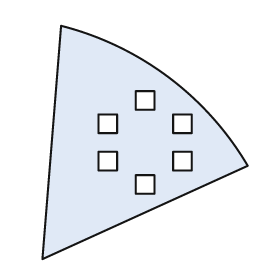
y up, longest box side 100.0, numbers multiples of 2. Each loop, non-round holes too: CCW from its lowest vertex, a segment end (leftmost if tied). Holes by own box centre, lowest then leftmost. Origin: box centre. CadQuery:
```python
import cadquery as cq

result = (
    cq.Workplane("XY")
    .moveTo(-44.0, -50.0)
    .lineTo(44.0, -10.0)
    .threePointArc((10.0, 28.0), (-36.0, 50.0))
    .close()
    .moveTo(-4.0, -22.0)
    .lineTo(4.0, -22.0)
    .lineTo(4.0, -14.0)
    .lineTo(-4.0, -14.0)
    .close()
    .moveTo(-20.0, -12.0)
    .lineTo(-12.0, -12.0)
    .lineTo(-12.0, -4.0)
    .lineTo(-20.0, -4.0)
    .close()
    .moveTo(12.0, -12.0)
    .lineTo(20.0, -12.0)
    .lineTo(20.0, -4.0)
    .lineTo(12.0, -4.0)
    .close()
    .moveTo(-20.0, 4.0)
    .lineTo(-12.0, 4.0)
    .lineTo(-12.0, 12.0)
    .lineTo(-20.0, 12.0)
    .close()
    .moveTo(12.0, 4.0)
    .lineTo(20.0, 4.0)
    .lineTo(20.0, 12.0)
    .lineTo(12.0, 12.0)
    .close()
    .moveTo(-4.0, 14.0)
    .lineTo(4.0, 14.0)
    .lineTo(4.0, 22.0)
    .lineTo(-4.0, 22.0)
    .close()
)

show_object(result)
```